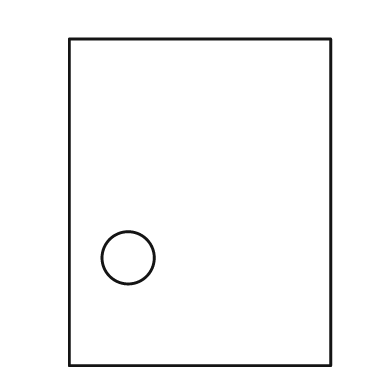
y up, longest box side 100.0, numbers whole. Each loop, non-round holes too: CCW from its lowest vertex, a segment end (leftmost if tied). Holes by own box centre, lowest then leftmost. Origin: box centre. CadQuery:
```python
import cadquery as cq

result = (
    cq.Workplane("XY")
    .moveTo(-40.0, -50.0)
    .lineTo(40.0, -50.0)
    .lineTo(40.0, 50.0)
    .lineTo(-40.0, 50.0)
    .close()
    .moveTo(-22.0, -17.0)
    .circle(8.0)
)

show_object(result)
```